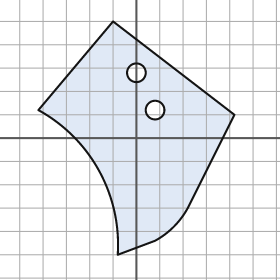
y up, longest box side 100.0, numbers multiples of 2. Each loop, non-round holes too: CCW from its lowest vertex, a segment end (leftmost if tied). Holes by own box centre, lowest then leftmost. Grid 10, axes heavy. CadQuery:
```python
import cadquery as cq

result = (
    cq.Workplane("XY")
    .moveTo(-8.0, -50.0)
    .lineTo(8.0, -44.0)
    .threePointArc((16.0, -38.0), (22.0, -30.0))
    .lineTo(42.0, 10.0)
    .lineTo(-10.0, 50.0)
    .lineTo(-42.0, 12.0)
    .threePointArc((-16.0, -14.0), (-8.0, -50.0))
    .close()
    .moveTo(8.0, 12.0)
    .circle(4.0)
    .moveTo(0.0, 28.0)
    .circle(4.0)
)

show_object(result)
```